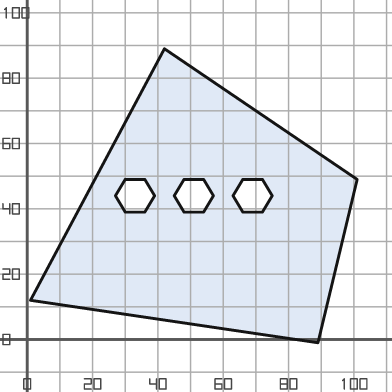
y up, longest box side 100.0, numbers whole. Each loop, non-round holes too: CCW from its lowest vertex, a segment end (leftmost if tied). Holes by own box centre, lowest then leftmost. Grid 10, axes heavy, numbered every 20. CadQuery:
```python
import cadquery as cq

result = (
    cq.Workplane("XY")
    .moveTo(89.0, -1.0)
    .lineTo(101.0, 49.0)
    .lineTo(42.0, 89.0)
    .lineTo(1.0, 12.0)
    .close()
    .moveTo(30.0, 39.0)
    .lineTo(36.0, 39.0)
    .lineTo(39.0, 44.0)
    .lineTo(36.0, 49.0)
    .lineTo(30.0, 49.0)
    .lineTo(27.0, 44.0)
    .close()
    .moveTo(48.0, 39.0)
    .lineTo(54.0, 39.0)
    .lineTo(57.0, 44.0)
    .lineTo(54.0, 49.0)
    .lineTo(48.0, 49.0)
    .lineTo(45.0, 44.0)
    .close()
    .moveTo(66.0, 39.0)
    .lineTo(72.0, 39.0)
    .lineTo(75.0, 44.0)
    .lineTo(72.0, 49.0)
    .lineTo(66.0, 49.0)
    .lineTo(63.0, 44.0)
    .close()
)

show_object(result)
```